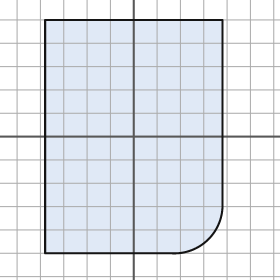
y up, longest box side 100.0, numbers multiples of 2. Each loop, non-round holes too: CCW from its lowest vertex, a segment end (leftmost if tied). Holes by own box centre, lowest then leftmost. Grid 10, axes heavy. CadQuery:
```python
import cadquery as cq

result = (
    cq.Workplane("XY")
    .moveTo(-38.0, -50.0)
    .lineTo(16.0, -50.0)
    .threePointArc((32.0, -44.0), (38.0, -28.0))
    .lineTo(38.0, 50.0)
    .lineTo(-38.0, 50.0)
    .close()
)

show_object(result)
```